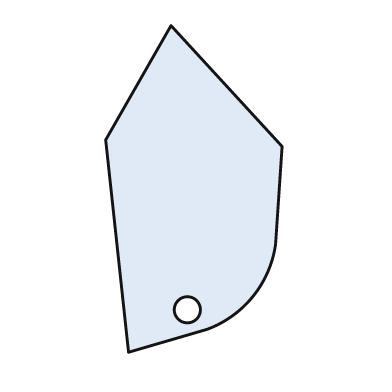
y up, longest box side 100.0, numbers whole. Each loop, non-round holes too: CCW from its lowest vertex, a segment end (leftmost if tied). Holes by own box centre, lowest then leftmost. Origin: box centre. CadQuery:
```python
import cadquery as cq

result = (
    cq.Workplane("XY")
    .moveTo(-20.0, -50.0)
    .lineTo(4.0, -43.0)
    .threePointArc((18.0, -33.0), (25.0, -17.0))
    .lineTo(27.0, 13.0)
    .lineTo(-7.0, 50.0)
    .lineTo(-27.0, 15.0)
    .close()
    .moveTo(-2.0, -37.0)
    .circle(4.0)
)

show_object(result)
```